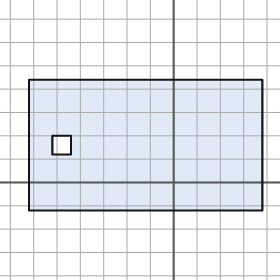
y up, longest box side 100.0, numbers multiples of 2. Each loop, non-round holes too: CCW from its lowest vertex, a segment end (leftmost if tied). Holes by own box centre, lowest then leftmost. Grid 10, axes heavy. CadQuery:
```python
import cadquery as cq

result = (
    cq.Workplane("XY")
    .moveTo(-62.0, -12.0)
    .lineTo(38.0, -12.0)
    .lineTo(38.0, 44.0)
    .lineTo(-62.0, 44.0)
    .close()
    .moveTo(-52.0, 12.0)
    .lineTo(-44.0, 12.0)
    .lineTo(-44.0, 20.0)
    .lineTo(-52.0, 20.0)
    .close()
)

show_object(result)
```